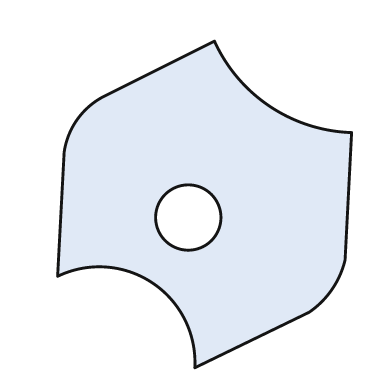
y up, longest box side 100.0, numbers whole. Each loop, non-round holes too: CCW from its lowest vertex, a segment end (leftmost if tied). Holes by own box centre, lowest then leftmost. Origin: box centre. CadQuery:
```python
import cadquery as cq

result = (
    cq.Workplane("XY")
    .moveTo(-3.0, -50.0)
    .lineTo(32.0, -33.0)
    .threePointArc((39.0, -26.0), (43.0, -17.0))
    .lineTo(45.0, 22.0)
    .threePointArc((20.0, 30.0), (3.0, 50.0))
    .lineTo(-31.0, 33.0)
    .threePointArc((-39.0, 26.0), (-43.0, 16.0))
    .lineTo(-45.0, -22.0)
    .threePointArc((-16.0, -24.0), (-3.0, -50.0))
    .close()
    .moveTo(-5.0, -4.0)
    .circle(10.0)
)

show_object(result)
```